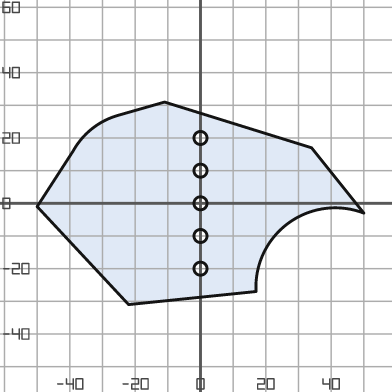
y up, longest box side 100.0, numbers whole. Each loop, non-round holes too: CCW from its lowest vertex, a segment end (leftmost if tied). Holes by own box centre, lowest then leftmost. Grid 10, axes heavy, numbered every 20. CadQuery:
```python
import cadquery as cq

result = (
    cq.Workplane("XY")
    .moveTo(-22.0, -31.0)
    .lineTo(17.0, -27.0)
    .threePointArc((27.0, -6.0), (50.0, -3.0))
    .lineTo(34.0, 17.0)
    .lineTo(-11.0, 31.0)
    .lineTo(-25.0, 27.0)
    .threePointArc((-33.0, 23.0), (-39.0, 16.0))
    .lineTo(-50.0, -1.0)
    .close()
    .moveTo(0.0, -20.0)
    .circle(2.0)
    .moveTo(0.0, -10.0)
    .circle(2.0)
    .moveTo(0.0, 0.0)
    .circle(2.0)
    .moveTo(0.0, 10.0)
    .circle(2.0)
    .moveTo(0.0, 20.0)
    .circle(2.0)
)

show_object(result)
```